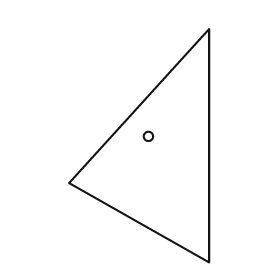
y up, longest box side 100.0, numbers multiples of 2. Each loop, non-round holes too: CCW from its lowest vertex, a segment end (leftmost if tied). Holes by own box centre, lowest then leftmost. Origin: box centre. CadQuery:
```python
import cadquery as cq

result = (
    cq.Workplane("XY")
    .moveTo(30.0, -50.0)
    .lineTo(30.0, 50.0)
    .lineTo(-30.0, -16.0)
    .close()
    .moveTo(4.0, 4.0)
    .circle(2.0)
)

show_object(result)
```